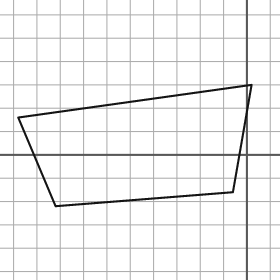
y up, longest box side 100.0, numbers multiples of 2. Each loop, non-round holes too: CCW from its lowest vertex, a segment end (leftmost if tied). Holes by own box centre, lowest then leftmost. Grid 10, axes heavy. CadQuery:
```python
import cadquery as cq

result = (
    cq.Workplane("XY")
    .moveTo(-82.0, -22.0)
    .lineTo(-6.0, -16.0)
    .lineTo(2.0, 30.0)
    .lineTo(-98.0, 16.0)
    .close()
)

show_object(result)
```